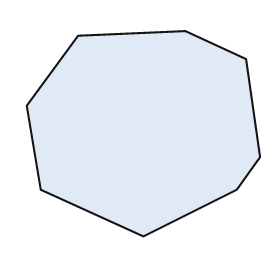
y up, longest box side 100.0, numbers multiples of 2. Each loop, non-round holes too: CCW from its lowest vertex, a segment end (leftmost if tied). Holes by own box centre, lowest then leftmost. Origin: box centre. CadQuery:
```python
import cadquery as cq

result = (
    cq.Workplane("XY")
    .moveTo(0.0, -44.0)
    .lineTo(40.0, -24.0)
    .lineTo(50.0, -10.0)
    .lineTo(44.0, 32.0)
    .lineTo(18.0, 44.0)
    .lineTo(-28.0, 42.0)
    .lineTo(-50.0, 12.0)
    .lineTo(-44.0, -24.0)
    .close()
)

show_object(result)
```